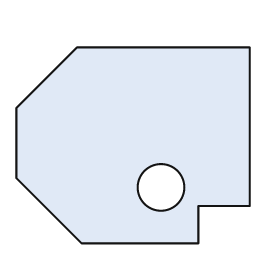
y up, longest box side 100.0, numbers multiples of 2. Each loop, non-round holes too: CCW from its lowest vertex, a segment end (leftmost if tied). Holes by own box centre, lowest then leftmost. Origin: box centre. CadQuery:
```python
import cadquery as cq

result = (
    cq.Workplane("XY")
    .moveTo(-22.0, -42.0)
    .lineTo(28.0, -42.0)
    .lineTo(28.0, -26.0)
    .lineTo(50.0, -26.0)
    .lineTo(50.0, 42.0)
    .lineTo(-24.0, 42.0)
    .lineTo(-50.0, 16.0)
    .lineTo(-50.0, -14.0)
    .close()
    .moveTo(12.0, -18.0)
    .circle(10.0)
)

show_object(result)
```